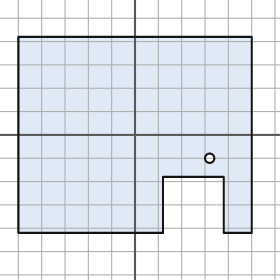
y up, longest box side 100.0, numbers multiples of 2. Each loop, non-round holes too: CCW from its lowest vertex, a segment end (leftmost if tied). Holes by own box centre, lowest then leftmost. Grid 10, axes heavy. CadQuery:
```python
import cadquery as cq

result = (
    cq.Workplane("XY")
    .moveTo(-50.0, -42.0)
    .lineTo(12.0, -42.0)
    .lineTo(12.0, -18.0)
    .lineTo(38.0, -18.0)
    .lineTo(38.0, -42.0)
    .lineTo(50.0, -42.0)
    .lineTo(50.0, 42.0)
    .lineTo(-50.0, 42.0)
    .close()
    .moveTo(32.0, -10.0)
    .circle(2.0)
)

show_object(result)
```